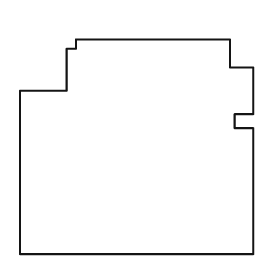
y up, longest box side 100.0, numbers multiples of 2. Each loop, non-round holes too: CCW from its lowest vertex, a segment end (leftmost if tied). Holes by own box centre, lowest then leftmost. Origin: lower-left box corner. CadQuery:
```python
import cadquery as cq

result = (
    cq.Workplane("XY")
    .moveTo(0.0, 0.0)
    .lineTo(100.0, 0.0)
    .lineTo(100.0, 54.0)
    .lineTo(92.0, 54.0)
    .lineTo(92.0, 60.0)
    .lineTo(100.0, 60.0)
    .lineTo(100.0, 80.0)
    .lineTo(90.0, 80.0)
    .lineTo(90.0, 92.0)
    .lineTo(24.0, 92.0)
    .lineTo(24.0, 88.0)
    .lineTo(20.0, 88.0)
    .lineTo(20.0, 70.0)
    .lineTo(0.0, 70.0)
    .close()
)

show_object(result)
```